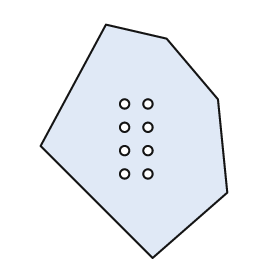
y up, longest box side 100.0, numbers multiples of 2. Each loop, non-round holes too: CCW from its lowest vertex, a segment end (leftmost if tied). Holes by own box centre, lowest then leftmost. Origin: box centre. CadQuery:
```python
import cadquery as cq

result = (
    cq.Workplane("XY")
    .moveTo(8.0, -50.0)
    .lineTo(40.0, -22.0)
    .lineTo(36.0, 18.0)
    .lineTo(14.0, 44.0)
    .lineTo(-12.0, 50.0)
    .lineTo(-40.0, -2.0)
    .close()
    .moveTo(-4.0, -14.0)
    .circle(2.0)
    .moveTo(6.0, -14.0)
    .circle(2.0)
    .moveTo(-4.0, -4.0)
    .circle(2.0)
    .moveTo(6.0, -4.0)
    .circle(2.0)
    .moveTo(-4.0, 6.0)
    .circle(2.0)
    .moveTo(6.0, 6.0)
    .circle(2.0)
    .moveTo(-4.0, 16.0)
    .circle(2.0)
    .moveTo(6.0, 16.0)
    .circle(2.0)
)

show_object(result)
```